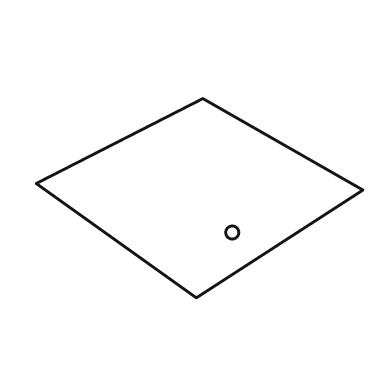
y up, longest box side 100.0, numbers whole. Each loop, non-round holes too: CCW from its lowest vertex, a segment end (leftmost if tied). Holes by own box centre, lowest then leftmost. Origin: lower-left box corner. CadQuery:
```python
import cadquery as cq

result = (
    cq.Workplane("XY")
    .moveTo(49.0, 0.0)
    .lineTo(100.0, 33.0)
    .lineTo(51.0, 61.0)
    .lineTo(0.0, 35.0)
    .close()
    .moveTo(60.0, 20.0)
    .circle(2.0)
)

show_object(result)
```